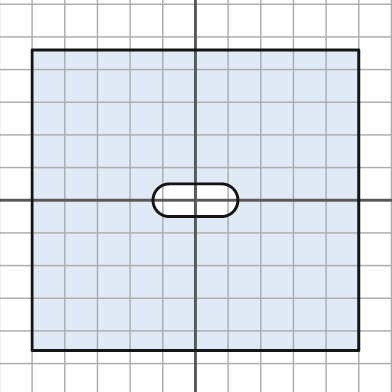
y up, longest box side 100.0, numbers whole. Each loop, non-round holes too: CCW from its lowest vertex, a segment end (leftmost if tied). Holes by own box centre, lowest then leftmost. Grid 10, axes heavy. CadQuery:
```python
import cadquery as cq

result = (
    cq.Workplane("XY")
    .moveTo(-50.0, -46.0)
    .lineTo(50.0, -46.0)
    .lineTo(50.0, 46.0)
    .lineTo(-50.0, 46.0)
    .close()
    .moveTo(-8.0, -5.0)
    .lineTo(8.0, -5.0)
    .threePointArc((13.0, 0.0), (8.0, 5.0))
    .lineTo(-8.0, 5.0)
    .threePointArc((-13.0, 0.0), (-8.0, -5.0))
    .close()
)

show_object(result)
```